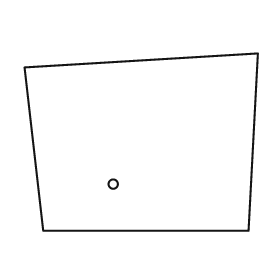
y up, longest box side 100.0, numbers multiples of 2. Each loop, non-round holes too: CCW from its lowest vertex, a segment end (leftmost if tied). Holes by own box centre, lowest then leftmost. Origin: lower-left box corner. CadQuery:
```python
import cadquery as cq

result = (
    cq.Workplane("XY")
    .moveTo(8.0, 0.0)
    .lineTo(96.0, 0.0)
    .lineTo(100.0, 76.0)
    .lineTo(0.0, 70.0)
    .close()
    .moveTo(38.0, 20.0)
    .circle(2.0)
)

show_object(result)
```